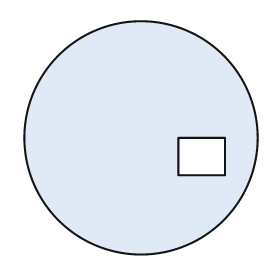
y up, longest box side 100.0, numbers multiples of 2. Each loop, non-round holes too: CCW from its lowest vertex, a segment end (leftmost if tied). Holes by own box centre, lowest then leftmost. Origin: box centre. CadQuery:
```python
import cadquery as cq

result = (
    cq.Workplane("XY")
    .moveTo(0.0, 0.0)
    .circle(50.0)
    .moveTo(16.0, -16.0)
    .lineTo(36.0, -16.0)
    .lineTo(36.0, 0.0)
    .lineTo(16.0, 0.0)
    .close()
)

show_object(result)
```